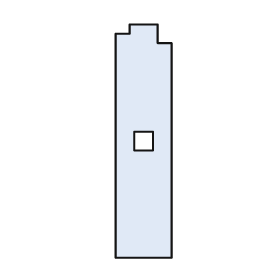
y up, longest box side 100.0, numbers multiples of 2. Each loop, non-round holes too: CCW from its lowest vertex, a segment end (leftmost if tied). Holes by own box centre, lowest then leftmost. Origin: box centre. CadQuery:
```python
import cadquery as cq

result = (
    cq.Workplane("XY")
    .moveTo(-12.0, -50.0)
    .lineTo(12.0, -50.0)
    .lineTo(12.0, 42.0)
    .lineTo(6.0, 42.0)
    .lineTo(6.0, 50.0)
    .lineTo(-6.0, 50.0)
    .lineTo(-6.0, 46.0)
    .lineTo(-12.0, 46.0)
    .close()
    .moveTo(-4.0, -4.0)
    .lineTo(4.0, -4.0)
    .lineTo(4.0, 4.0)
    .lineTo(-4.0, 4.0)
    .close()
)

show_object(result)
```